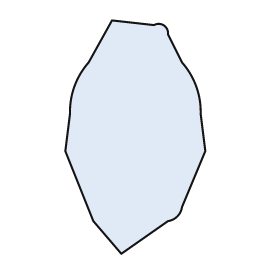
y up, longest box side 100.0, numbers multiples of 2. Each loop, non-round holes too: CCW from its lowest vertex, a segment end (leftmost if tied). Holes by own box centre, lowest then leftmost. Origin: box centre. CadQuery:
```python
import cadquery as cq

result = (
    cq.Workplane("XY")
    .moveTo(-6.0, -50.0)
    .lineTo(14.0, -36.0)
    .threePointArc((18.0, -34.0), (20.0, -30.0))
    .lineTo(30.0, -6.0)
    .lineTo(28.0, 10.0)
    .threePointArc((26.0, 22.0), (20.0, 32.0))
    .lineTo(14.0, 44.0)
    .threePointArc((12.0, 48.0), (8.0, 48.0))
    .lineTo(-10.0, 50.0)
    .lineTo(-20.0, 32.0)
    .threePointArc((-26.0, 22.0), (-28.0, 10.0))
    .lineTo(-30.0, -6.0)
    .lineTo(-18.0, -36.0)
    .close()
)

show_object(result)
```